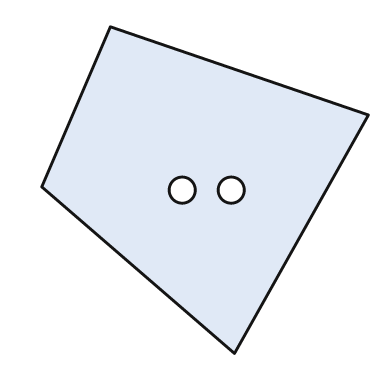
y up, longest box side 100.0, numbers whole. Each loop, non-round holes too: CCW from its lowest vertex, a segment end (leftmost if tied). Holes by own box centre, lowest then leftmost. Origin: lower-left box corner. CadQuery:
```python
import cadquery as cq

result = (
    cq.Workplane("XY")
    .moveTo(59.0, 0.0)
    .lineTo(100.0, 73.0)
    .lineTo(21.0, 100.0)
    .lineTo(0.0, 51.0)
    .close()
    .moveTo(43.0, 50.0)
    .circle(4.0)
    .moveTo(58.0, 50.0)
    .circle(4.0)
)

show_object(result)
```